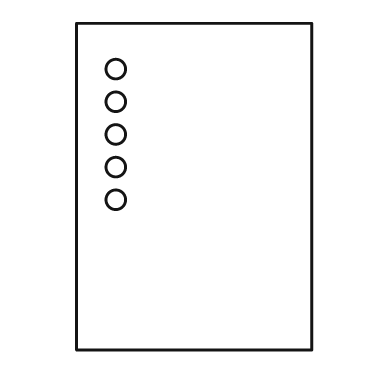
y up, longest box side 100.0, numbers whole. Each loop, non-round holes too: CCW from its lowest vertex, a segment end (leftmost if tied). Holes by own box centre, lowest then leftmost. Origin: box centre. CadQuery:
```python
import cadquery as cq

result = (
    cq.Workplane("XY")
    .moveTo(-36.0, -50.0)
    .lineTo(36.0, -50.0)
    .lineTo(36.0, 50.0)
    .lineTo(-36.0, 50.0)
    .close()
    .moveTo(-24.0, -4.0)
    .circle(3.0)
    .moveTo(-24.0, 6.0)
    .circle(3.0)
    .moveTo(-24.0, 16.0)
    .circle(3.0)
    .moveTo(-24.0, 26.0)
    .circle(3.0)
    .moveTo(-24.0, 36.0)
    .circle(3.0)
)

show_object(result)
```